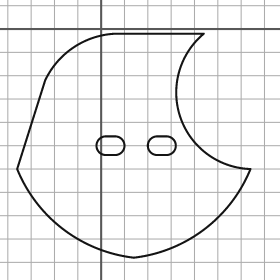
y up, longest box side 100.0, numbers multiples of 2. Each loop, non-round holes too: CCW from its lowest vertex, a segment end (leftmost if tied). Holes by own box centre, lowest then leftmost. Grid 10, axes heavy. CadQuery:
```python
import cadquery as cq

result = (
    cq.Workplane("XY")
    .moveTo(14.0, -98.0)
    .threePointArc((44.0, -86.0), (64.0, -60.0))
    .threePointArc((34.0, -38.0), (44.0, -2.0))
    .lineTo(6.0, -2.0)
    .threePointArc((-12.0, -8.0), (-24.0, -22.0))
    .lineTo(-36.0, -60.0)
    .threePointArc((-16.0, -86.0), (14.0, -98.0))
    .close()
    .moveTo(2.0, -54.0)
    .lineTo(6.0, -54.0)
    .threePointArc((10.0, -50.0), (6.0, -46.0))
    .lineTo(2.0, -46.0)
    .threePointArc((-2.0, -50.0), (2.0, -54.0))
    .close()
    .moveTo(24.0, -54.0)
    .lineTo(28.0, -54.0)
    .threePointArc((32.0, -50.0), (28.0, -46.0))
    .lineTo(24.0, -46.0)
    .threePointArc((20.0, -50.0), (24.0, -54.0))
    .close()
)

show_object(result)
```